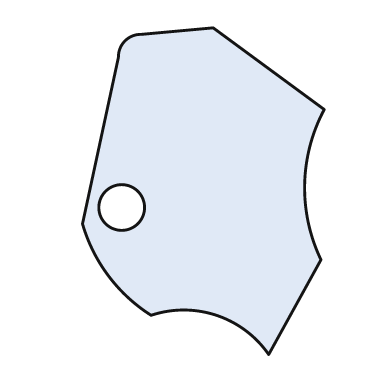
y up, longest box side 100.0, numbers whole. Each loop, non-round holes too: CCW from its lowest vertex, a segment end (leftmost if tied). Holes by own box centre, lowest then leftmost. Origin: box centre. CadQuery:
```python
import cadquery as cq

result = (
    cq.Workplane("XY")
    .moveTo(20.0, -50.0)
    .lineTo(36.0, -21.0)
    .threePointArc((31.0, 2.0), (37.0, 25.0))
    .lineTo(3.0, 50.0)
    .lineTo(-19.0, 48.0)
    .threePointArc((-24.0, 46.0), (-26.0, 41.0))
    .lineTo(-37.0, -10.0)
    .threePointArc((-29.0, -26.0), (-16.0, -38.0))
    .threePointArc((4.0, -38.0), (20.0, -50.0))
    .close()
    .moveTo(-25.0, -5.0)
    .circle(7.0)
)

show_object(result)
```